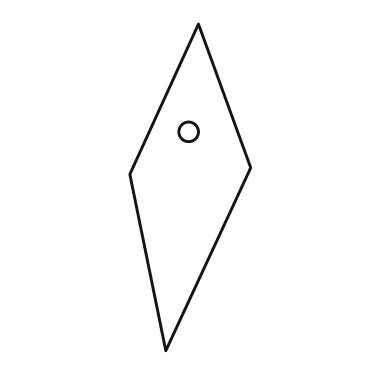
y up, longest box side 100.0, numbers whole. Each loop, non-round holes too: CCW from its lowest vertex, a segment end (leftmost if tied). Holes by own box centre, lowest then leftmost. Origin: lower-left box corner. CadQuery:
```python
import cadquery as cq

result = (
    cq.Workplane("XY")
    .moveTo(11.0, 0.0)
    .lineTo(37.0, 56.0)
    .lineTo(21.0, 100.0)
    .lineTo(0.0, 54.0)
    .close()
    .moveTo(18.0, 67.0)
    .circle(3.0)
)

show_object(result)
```